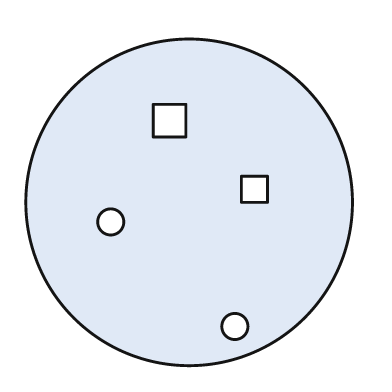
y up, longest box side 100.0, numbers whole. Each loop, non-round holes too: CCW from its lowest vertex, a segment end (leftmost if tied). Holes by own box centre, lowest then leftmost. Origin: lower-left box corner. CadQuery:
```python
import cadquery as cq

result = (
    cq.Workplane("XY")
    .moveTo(50.0, 50.0)
    .circle(50.0)
    .moveTo(64.0, 12.0)
    .circle(4.0)
    .moveTo(26.0, 44.0)
    .circle(4.0)
    .moveTo(66.0, 50.0)
    .lineTo(74.0, 50.0)
    .lineTo(74.0, 58.0)
    .lineTo(66.0, 58.0)
    .close()
    .moveTo(39.0, 70.0)
    .lineTo(49.0, 70.0)
    .lineTo(49.0, 80.0)
    .lineTo(39.0, 80.0)
    .close()
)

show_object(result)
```